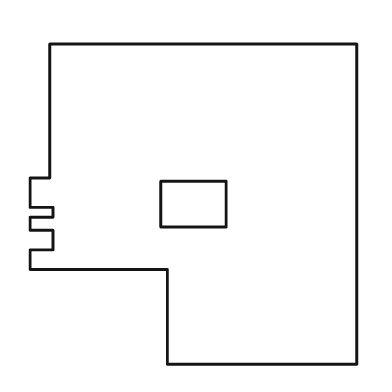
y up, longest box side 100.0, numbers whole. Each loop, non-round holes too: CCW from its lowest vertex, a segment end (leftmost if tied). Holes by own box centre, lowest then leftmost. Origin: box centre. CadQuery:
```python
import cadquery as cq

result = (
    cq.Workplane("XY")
    .moveTo(-8.0, -49.0)
    .lineTo(50.0, -49.0)
    .lineTo(50.0, 49.0)
    .lineTo(-44.0, 49.0)
    .lineTo(-44.0, 8.0)
    .lineTo(-50.0, 8.0)
    .lineTo(-50.0, -1.0)
    .lineTo(-43.0, -1.0)
    .lineTo(-43.0, -4.0)
    .lineTo(-50.0, -4.0)
    .lineTo(-50.0, -8.0)
    .lineTo(-43.0, -8.0)
    .lineTo(-43.0, -14.0)
    .lineTo(-50.0, -14.0)
    .lineTo(-50.0, -20.0)
    .lineTo(-8.0, -20.0)
    .close()
    .moveTo(-10.0, -7.0)
    .lineTo(10.0, -7.0)
    .lineTo(10.0, 7.0)
    .lineTo(-10.0, 7.0)
    .close()
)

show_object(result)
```